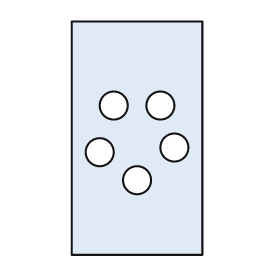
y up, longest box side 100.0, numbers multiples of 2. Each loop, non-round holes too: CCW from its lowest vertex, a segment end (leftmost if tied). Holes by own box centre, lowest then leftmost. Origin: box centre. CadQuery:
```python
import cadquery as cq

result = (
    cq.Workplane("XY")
    .moveTo(-28.0, -50.0)
    .lineTo(28.0, -50.0)
    .lineTo(28.0, 50.0)
    .lineTo(-28.0, 50.0)
    .close()
    .moveTo(0.0, -18.0)
    .circle(6.0)
    .moveTo(-16.0, -6.0)
    .circle(6.0)
    .moveTo(16.0, -4.0)
    .circle(6.0)
    .moveTo(-10.0, 14.0)
    .circle(6.0)
    .moveTo(10.0, 14.0)
    .circle(6.0)
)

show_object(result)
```